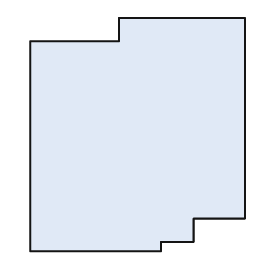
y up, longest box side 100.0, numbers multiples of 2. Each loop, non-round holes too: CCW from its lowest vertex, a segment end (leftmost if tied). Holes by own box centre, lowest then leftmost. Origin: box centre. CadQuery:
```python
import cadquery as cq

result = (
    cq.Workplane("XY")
    .moveTo(-46.0, -50.0)
    .lineTo(10.0, -50.0)
    .lineTo(10.0, -46.0)
    .lineTo(24.0, -46.0)
    .lineTo(24.0, -36.0)
    .lineTo(46.0, -36.0)
    .lineTo(46.0, 50.0)
    .lineTo(-8.0, 50.0)
    .lineTo(-8.0, 40.0)
    .lineTo(-46.0, 40.0)
    .close()
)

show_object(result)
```